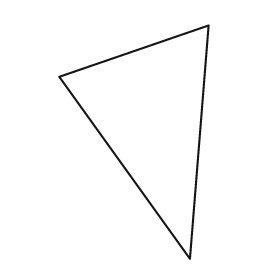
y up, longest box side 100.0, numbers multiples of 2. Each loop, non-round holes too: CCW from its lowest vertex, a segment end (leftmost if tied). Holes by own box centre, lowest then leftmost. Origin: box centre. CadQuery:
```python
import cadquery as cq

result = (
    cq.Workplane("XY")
    .moveTo(24.0, -50.0)
    .lineTo(32.0, 50.0)
    .lineTo(-32.0, 28.0)
    .close()
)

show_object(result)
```